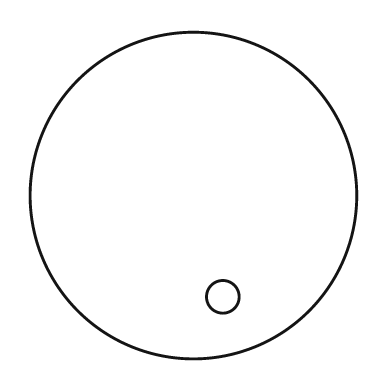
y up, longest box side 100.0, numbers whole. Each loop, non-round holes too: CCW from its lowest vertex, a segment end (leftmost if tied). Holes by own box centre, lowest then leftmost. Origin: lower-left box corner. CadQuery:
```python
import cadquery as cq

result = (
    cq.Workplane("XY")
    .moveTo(50.0, 50.0)
    .circle(50.0)
    .moveTo(59.0, 19.0)
    .circle(5.0)
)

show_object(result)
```